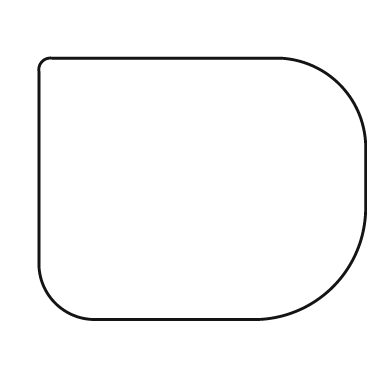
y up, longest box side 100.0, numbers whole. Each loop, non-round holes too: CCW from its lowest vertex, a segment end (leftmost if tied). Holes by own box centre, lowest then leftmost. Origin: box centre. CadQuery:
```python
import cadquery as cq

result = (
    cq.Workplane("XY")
    .moveTo(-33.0, -40.0)
    .lineTo(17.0, -40.0)
    .threePointArc((40.0, -30.0), (50.0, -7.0))
    .lineTo(50.0, 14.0)
    .threePointArc((42.0, 32.0), (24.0, 40.0))
    .lineTo(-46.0, 40.0)
    .threePointArc((-49.0, 39.0), (-50.0, 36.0))
    .lineTo(-50.0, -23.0)
    .threePointArc((-45.0, -35.0), (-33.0, -40.0))
    .close()
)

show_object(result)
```